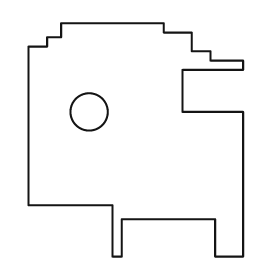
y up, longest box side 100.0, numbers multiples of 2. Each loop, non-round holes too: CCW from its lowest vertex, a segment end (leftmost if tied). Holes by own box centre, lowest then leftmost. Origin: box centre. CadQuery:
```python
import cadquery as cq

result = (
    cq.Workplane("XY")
    .moveTo(-10.0, -50.0)
    .lineTo(-6.0, -50.0)
    .lineTo(-6.0, -34.0)
    .lineTo(34.0, -34.0)
    .lineTo(34.0, -50.0)
    .lineTo(46.0, -50.0)
    .lineTo(46.0, 12.0)
    .lineTo(20.0, 12.0)
    .lineTo(20.0, 30.0)
    .lineTo(46.0, 30.0)
    .lineTo(46.0, 34.0)
    .lineTo(32.0, 34.0)
    .lineTo(32.0, 38.0)
    .lineTo(24.0, 38.0)
    .lineTo(24.0, 46.0)
    .lineTo(12.0, 46.0)
    .lineTo(12.0, 50.0)
    .lineTo(-32.0, 50.0)
    .lineTo(-32.0, 44.0)
    .lineTo(-38.0, 44.0)
    .lineTo(-38.0, 40.0)
    .lineTo(-46.0, 40.0)
    .lineTo(-46.0, -28.0)
    .lineTo(-10.0, -28.0)
    .close()
    .moveTo(-20.0, 12.0)
    .circle(8.0)
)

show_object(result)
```